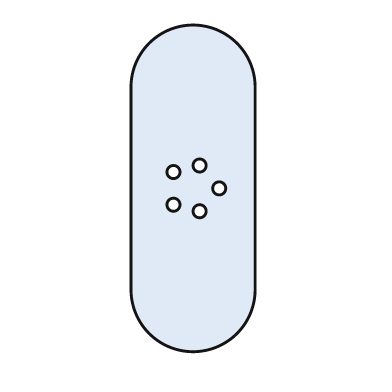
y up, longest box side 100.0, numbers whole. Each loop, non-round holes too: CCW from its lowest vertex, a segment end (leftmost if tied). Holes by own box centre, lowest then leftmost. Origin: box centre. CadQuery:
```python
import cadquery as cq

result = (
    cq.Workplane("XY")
    .moveTo(-19.0, -31.0)
    .threePointArc((0.0, -50.0), (19.0, -31.0))
    .lineTo(19.0, 31.0)
    .threePointArc((0.0, 50.0), (-19.0, 31.0))
    .close()
    .moveTo(2.0, -7.0)
    .circle(2.0)
    .moveTo(-6.0, -5.0)
    .circle(2.0)
    .moveTo(8.0, 0.0)
    .circle(2.0)
    .moveTo(-6.0, 5.0)
    .circle(2.0)
    .moveTo(2.0, 7.0)
    .circle(2.0)
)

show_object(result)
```